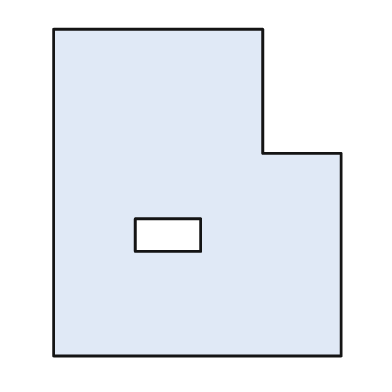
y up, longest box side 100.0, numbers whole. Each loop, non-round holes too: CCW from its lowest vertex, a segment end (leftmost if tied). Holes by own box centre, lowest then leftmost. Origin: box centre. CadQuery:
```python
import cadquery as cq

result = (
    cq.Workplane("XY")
    .moveTo(-44.0, -50.0)
    .lineTo(44.0, -50.0)
    .lineTo(44.0, 12.0)
    .lineTo(20.0, 12.0)
    .lineTo(20.0, 50.0)
    .lineTo(-44.0, 50.0)
    .close()
    .moveTo(-19.0, -18.0)
    .lineTo(1.0, -18.0)
    .lineTo(1.0, -8.0)
    .lineTo(-19.0, -8.0)
    .close()
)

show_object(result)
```